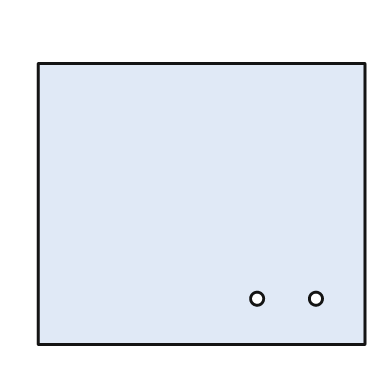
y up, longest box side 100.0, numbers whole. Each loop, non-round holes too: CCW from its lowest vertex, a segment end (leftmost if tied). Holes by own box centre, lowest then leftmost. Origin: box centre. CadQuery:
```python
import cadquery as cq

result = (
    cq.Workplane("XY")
    .moveTo(-50.0, -43.0)
    .lineTo(50.0, -43.0)
    .lineTo(50.0, 43.0)
    .lineTo(-50.0, 43.0)
    .close()
    .moveTo(17.0, -29.0)
    .circle(2.0)
    .moveTo(35.0, -29.0)
    .circle(2.0)
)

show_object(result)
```